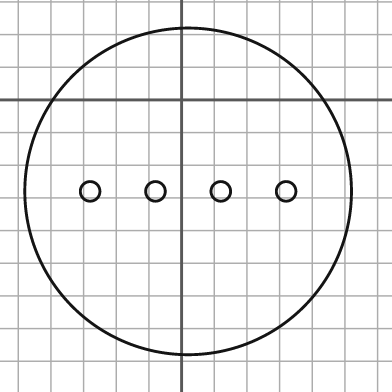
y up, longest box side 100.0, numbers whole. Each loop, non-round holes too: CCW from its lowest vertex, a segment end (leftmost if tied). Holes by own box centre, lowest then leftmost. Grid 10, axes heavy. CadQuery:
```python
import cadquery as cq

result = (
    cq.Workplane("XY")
    .moveTo(2.0, -28.0)
    .circle(50.0)
    .moveTo(-28.0, -28.0)
    .circle(3.0)
    .moveTo(-8.0, -28.0)
    .circle(3.0)
    .moveTo(12.0, -28.0)
    .circle(3.0)
    .moveTo(32.0, -28.0)
    .circle(3.0)
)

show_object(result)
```